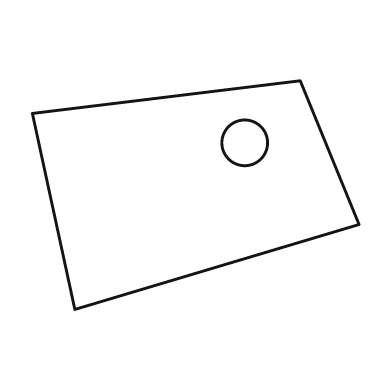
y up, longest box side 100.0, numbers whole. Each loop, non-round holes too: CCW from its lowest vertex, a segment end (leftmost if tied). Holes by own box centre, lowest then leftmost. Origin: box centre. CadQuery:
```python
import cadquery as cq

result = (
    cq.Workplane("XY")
    .moveTo(-37.0, -35.0)
    .lineTo(50.0, -9.0)
    .lineTo(32.0, 35.0)
    .lineTo(-50.0, 25.0)
    .close()
    .moveTo(15.0, 16.0)
    .circle(7.0)
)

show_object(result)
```